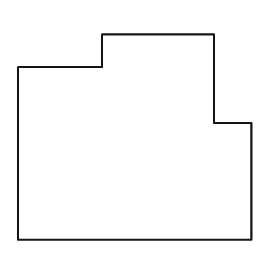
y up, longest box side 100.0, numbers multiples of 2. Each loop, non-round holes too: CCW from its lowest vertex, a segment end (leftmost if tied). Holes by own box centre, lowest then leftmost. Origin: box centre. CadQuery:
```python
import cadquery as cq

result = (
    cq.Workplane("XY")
    .moveTo(-50.0, -44.0)
    .lineTo(50.0, -44.0)
    .lineTo(50.0, 6.0)
    .lineTo(34.0, 6.0)
    .lineTo(34.0, 44.0)
    .lineTo(-14.0, 44.0)
    .lineTo(-14.0, 30.0)
    .lineTo(-50.0, 30.0)
    .close()
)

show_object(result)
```